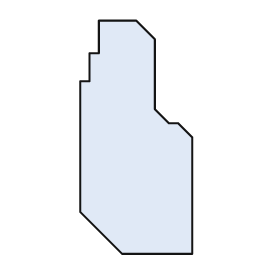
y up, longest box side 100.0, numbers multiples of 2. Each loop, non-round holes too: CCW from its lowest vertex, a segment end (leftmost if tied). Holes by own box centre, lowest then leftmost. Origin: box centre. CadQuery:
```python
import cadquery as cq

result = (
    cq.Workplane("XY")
    .moveTo(-6.0, -50.0)
    .lineTo(24.0, -50.0)
    .lineTo(24.0, 0.0)
    .lineTo(18.0, 6.0)
    .lineTo(14.0, 6.0)
    .lineTo(8.0, 12.0)
    .lineTo(8.0, 42.0)
    .lineTo(0.0, 50.0)
    .lineTo(-16.0, 50.0)
    .lineTo(-16.0, 36.0)
    .lineTo(-20.0, 36.0)
    .lineTo(-20.0, 24.0)
    .lineTo(-24.0, 24.0)
    .lineTo(-24.0, -32.0)
    .close()
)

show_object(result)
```